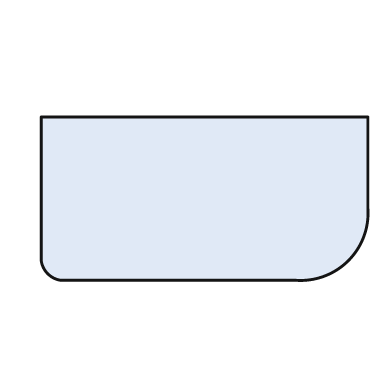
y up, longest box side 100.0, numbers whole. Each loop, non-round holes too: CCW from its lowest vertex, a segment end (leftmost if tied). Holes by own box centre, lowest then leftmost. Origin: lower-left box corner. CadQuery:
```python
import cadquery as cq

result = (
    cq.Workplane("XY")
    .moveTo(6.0, 0.0)
    .lineTo(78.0, 0.0)
    .threePointArc((94.0, 6.0), (100.0, 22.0))
    .lineTo(100.0, 50.0)
    .lineTo(0.0, 50.0)
    .lineTo(0.0, 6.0)
    .threePointArc((2.0, 2.0), (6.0, 0.0))
    .close()
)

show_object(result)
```